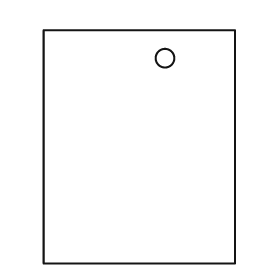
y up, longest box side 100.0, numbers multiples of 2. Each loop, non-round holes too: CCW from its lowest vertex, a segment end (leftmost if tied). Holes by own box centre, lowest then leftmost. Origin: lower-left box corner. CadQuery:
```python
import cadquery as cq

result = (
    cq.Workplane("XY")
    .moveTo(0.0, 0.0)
    .lineTo(82.0, 0.0)
    .lineTo(82.0, 100.0)
    .lineTo(0.0, 100.0)
    .close()
    .moveTo(52.0, 88.0)
    .circle(4.0)
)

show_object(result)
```